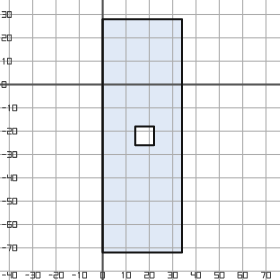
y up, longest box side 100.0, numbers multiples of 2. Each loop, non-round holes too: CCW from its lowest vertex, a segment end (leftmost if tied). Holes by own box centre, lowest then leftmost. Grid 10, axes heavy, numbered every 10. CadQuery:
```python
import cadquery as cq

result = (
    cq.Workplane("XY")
    .moveTo(0.0, -72.0)
    .lineTo(34.0, -72.0)
    .lineTo(34.0, 28.0)
    .lineTo(0.0, 28.0)
    .close()
    .moveTo(14.0, -26.0)
    .lineTo(22.0, -26.0)
    .lineTo(22.0, -18.0)
    .lineTo(14.0, -18.0)
    .close()
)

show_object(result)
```